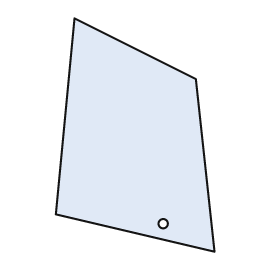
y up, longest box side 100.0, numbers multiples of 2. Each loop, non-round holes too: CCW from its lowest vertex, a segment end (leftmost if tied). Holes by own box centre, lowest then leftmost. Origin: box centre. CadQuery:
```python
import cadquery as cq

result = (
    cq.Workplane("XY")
    .moveTo(34.0, -50.0)
    .lineTo(26.0, 24.0)
    .lineTo(-26.0, 50.0)
    .lineTo(-34.0, -34.0)
    .close()
    .moveTo(12.0, -38.0)
    .circle(2.0)
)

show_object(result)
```